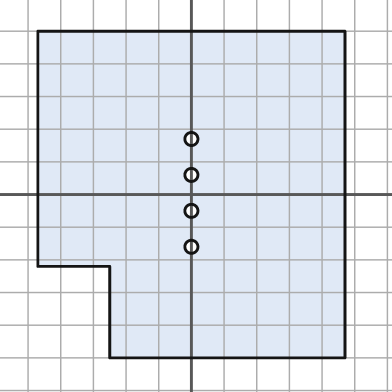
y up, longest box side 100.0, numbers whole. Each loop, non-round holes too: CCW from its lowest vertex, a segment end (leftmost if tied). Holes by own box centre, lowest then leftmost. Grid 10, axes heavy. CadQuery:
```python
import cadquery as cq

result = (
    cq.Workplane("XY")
    .moveTo(-25.0, -50.0)
    .lineTo(47.0, -50.0)
    .lineTo(47.0, 50.0)
    .lineTo(-47.0, 50.0)
    .lineTo(-47.0, -22.0)
    .lineTo(-25.0, -22.0)
    .close()
    .moveTo(0.0, -16.0)
    .circle(2.0)
    .moveTo(0.0, -5.0)
    .circle(2.0)
    .moveTo(0.0, 6.0)
    .circle(2.0)
    .moveTo(0.0, 17.0)
    .circle(2.0)
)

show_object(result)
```